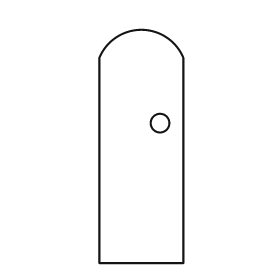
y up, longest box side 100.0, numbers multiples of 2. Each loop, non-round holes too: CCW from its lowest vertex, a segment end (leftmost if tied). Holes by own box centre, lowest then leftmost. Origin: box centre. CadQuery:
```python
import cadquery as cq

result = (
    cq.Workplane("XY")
    .moveTo(-18.0, -50.0)
    .lineTo(18.0, -50.0)
    .lineTo(18.0, 38.0)
    .threePointArc((0.0, 50.0), (-18.0, 38.0))
    .close()
    .moveTo(8.0, 10.0)
    .circle(4.0)
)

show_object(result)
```